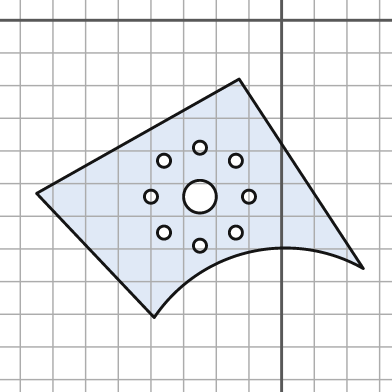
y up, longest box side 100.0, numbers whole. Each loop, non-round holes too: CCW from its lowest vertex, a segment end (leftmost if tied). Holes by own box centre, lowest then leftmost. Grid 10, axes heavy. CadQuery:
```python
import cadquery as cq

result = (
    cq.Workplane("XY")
    .moveTo(-39.0, -91.0)
    .threePointArc((-10.0, -71.0), (25.0, -76.0))
    .lineTo(-13.0, -18.0)
    .lineTo(-75.0, -53.0)
    .close()
    .moveTo(-25.0, -69.0)
    .circle(2.0)
    .moveTo(-36.0, -65.0)
    .circle(2.0)
    .moveTo(-14.0, -65.0)
    .circle(2.0)
    .moveTo(-40.0, -54.0)
    .circle(2.0)
    .moveTo(-25.0, -54.0)
    .circle(5.0)
    .moveTo(-10.0, -54.0)
    .circle(2.0)
    .moveTo(-36.0, -43.0)
    .circle(2.0)
    .moveTo(-14.0, -43.0)
    .circle(2.0)
    .moveTo(-25.0, -39.0)
    .circle(2.0)
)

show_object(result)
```